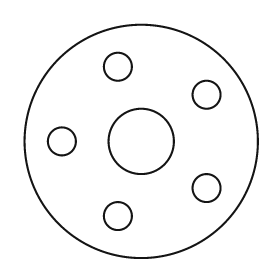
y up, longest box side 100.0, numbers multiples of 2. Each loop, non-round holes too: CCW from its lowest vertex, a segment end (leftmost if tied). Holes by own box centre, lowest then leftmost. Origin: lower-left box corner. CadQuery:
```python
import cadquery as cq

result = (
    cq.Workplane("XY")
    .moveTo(50.0, 50.0)
    .circle(50.0)
    .moveTo(40.0, 18.0)
    .circle(6.0)
    .moveTo(78.0, 30.0)
    .circle(6.0)
    .moveTo(16.0, 50.0)
    .circle(6.0)
    .moveTo(50.0, 50.0)
    .circle(14.0)
    .moveTo(78.0, 70.0)
    .circle(6.0)
    .moveTo(40.0, 82.0)
    .circle(6.0)
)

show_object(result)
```